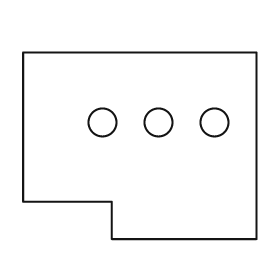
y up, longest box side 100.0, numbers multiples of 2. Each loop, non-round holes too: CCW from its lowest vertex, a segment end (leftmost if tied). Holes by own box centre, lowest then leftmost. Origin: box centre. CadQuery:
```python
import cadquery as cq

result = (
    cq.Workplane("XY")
    .moveTo(-12.0, -40.0)
    .lineTo(50.0, -40.0)
    .lineTo(50.0, 40.0)
    .lineTo(-50.0, 40.0)
    .lineTo(-50.0, -24.0)
    .lineTo(-12.0, -24.0)
    .close()
    .moveTo(-16.0, 10.0)
    .circle(6.0)
    .moveTo(8.0, 10.0)
    .circle(6.0)
    .moveTo(32.0, 10.0)
    .circle(6.0)
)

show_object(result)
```